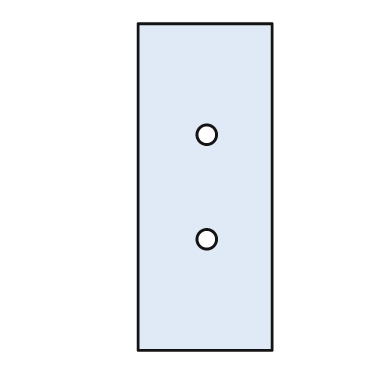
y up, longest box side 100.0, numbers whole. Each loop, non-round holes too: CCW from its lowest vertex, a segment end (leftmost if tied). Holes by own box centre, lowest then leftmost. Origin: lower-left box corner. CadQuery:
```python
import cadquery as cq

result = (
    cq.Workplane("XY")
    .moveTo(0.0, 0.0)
    .lineTo(41.0, 0.0)
    .lineTo(41.0, 100.0)
    .lineTo(0.0, 100.0)
    .close()
    .moveTo(21.0, 34.0)
    .circle(3.0)
    .moveTo(21.0, 66.0)
    .circle(3.0)
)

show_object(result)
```